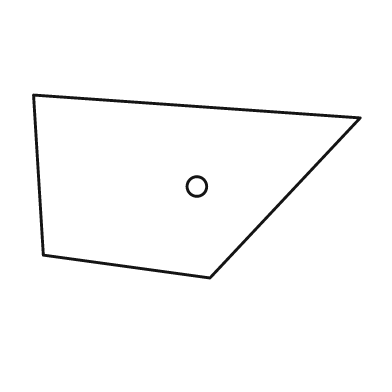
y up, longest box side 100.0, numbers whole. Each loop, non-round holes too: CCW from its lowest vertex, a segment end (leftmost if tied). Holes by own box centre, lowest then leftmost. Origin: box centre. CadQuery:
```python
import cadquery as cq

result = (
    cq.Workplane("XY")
    .moveTo(4.0, -28.0)
    .lineTo(50.0, 21.0)
    .lineTo(-50.0, 28.0)
    .lineTo(-47.0, -21.0)
    .close()
    .moveTo(0.0, 0.0)
    .circle(3.0)
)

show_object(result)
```